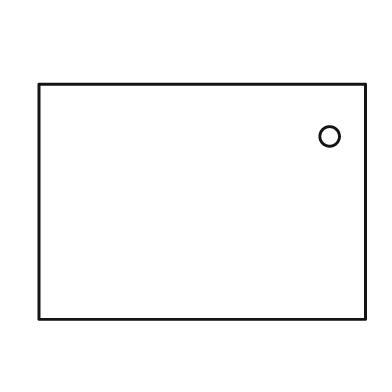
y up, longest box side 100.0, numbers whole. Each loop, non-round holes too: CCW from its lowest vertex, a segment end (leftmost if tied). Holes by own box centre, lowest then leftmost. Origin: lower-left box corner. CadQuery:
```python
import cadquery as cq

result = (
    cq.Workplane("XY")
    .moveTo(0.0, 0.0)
    .lineTo(100.0, 0.0)
    .lineTo(100.0, 72.0)
    .lineTo(0.0, 72.0)
    .close()
    .moveTo(89.0, 56.0)
    .circle(3.0)
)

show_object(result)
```